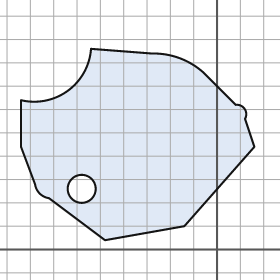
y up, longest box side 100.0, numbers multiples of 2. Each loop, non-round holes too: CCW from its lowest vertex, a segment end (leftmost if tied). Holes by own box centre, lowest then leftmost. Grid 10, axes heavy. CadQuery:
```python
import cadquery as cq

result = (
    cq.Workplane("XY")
    .moveTo(-48.0, 4.0)
    .lineTo(-14.0, 10.0)
    .lineTo(16.0, 44.0)
    .lineTo(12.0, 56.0)
    .threePointArc((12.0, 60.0), (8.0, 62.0))
    .lineTo(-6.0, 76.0)
    .threePointArc((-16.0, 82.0), (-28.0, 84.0))
    .lineTo(-54.0, 86.0)
    .threePointArc((-64.0, 68.0), (-84.0, 64.0))
    .lineTo(-84.0, 44.0)
    .lineTo(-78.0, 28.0)
    .threePointArc((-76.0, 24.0), (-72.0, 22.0))
    .close()
    .moveTo(-58.0, 26.0)
    .circle(6.0)
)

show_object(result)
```